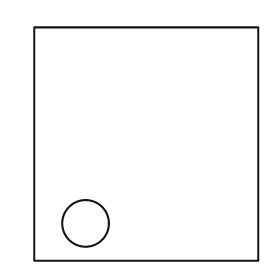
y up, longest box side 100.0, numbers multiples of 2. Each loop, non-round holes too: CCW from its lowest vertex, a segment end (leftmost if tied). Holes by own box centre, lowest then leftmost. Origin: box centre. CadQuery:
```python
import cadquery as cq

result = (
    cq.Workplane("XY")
    .moveTo(-48.0, -50.0)
    .lineTo(48.0, -50.0)
    .lineTo(48.0, 50.0)
    .lineTo(-48.0, 50.0)
    .close()
    .moveTo(-26.0, -34.0)
    .circle(10.0)
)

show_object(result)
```